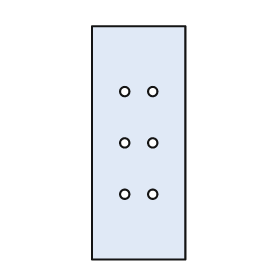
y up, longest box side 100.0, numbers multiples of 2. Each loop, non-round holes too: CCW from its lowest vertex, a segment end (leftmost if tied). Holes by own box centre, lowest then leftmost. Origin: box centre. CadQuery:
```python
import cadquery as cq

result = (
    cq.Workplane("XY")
    .moveTo(-20.0, -50.0)
    .lineTo(20.0, -50.0)
    .lineTo(20.0, 50.0)
    .lineTo(-20.0, 50.0)
    .close()
    .moveTo(-6.0, -22.0)
    .circle(2.0)
    .moveTo(6.0, -22.0)
    .circle(2.0)
    .moveTo(-6.0, 0.0)
    .circle(2.0)
    .moveTo(6.0, 0.0)
    .circle(2.0)
    .moveTo(-6.0, 22.0)
    .circle(2.0)
    .moveTo(6.0, 22.0)
    .circle(2.0)
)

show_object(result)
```